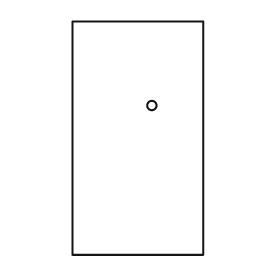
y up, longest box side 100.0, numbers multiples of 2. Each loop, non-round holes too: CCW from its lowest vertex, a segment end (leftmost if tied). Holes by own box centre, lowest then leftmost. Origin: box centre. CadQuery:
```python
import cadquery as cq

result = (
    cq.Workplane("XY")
    .moveTo(-28.0, -50.0)
    .lineTo(28.0, -50.0)
    .lineTo(28.0, 50.0)
    .lineTo(-28.0, 50.0)
    .close()
    .moveTo(6.0, 14.0)
    .circle(2.0)
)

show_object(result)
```